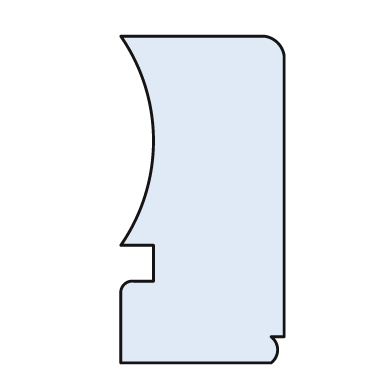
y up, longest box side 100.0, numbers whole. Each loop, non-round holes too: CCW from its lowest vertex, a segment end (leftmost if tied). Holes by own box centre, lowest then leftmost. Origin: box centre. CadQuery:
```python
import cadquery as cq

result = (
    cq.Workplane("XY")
    .moveTo(-25.0, -50.0)
    .lineTo(21.0, -50.0)
    .threePointArc((23.0, -46.0), (21.0, -42.0))
    .lineTo(25.0, -42.0)
    .lineTo(25.0, 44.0)
    .threePointArc((23.0, 48.0), (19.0, 50.0))
    .lineTo(-25.0, 50.0)
    .threePointArc((-15.0, 18.0), (-25.0, -14.0))
    .lineTo(-15.0, -14.0)
    .lineTo(-15.0, -25.0)
    .lineTo(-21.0, -25.0)
    .threePointArc((-24.0, -26.0), (-25.0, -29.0))
    .close()
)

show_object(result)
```